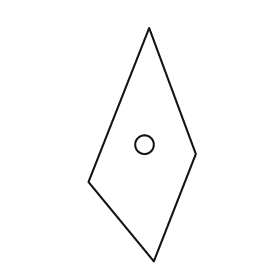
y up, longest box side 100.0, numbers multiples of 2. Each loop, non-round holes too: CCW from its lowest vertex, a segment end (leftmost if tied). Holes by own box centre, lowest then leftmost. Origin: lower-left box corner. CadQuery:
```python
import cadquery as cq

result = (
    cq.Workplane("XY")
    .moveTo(28.0, 0.0)
    .lineTo(46.0, 46.0)
    .lineTo(26.0, 100.0)
    .lineTo(0.0, 34.0)
    .close()
    .moveTo(24.0, 50.0)
    .circle(4.0)
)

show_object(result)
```